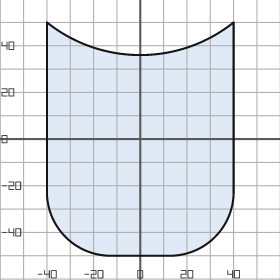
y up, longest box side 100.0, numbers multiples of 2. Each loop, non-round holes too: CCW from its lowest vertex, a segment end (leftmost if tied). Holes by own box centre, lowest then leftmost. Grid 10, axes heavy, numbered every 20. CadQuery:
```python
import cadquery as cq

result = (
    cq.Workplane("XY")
    .moveTo(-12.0, -50.0)
    .lineTo(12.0, -50.0)
    .threePointArc((32.0, -42.0), (40.0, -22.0))
    .lineTo(40.0, 50.0)
    .threePointArc((0.0, 36.0), (-40.0, 50.0))
    .lineTo(-40.0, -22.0)
    .threePointArc((-32.0, -42.0), (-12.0, -50.0))
    .close()
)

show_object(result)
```